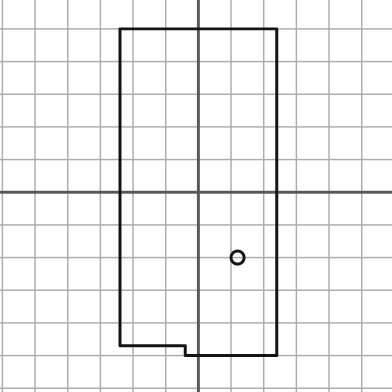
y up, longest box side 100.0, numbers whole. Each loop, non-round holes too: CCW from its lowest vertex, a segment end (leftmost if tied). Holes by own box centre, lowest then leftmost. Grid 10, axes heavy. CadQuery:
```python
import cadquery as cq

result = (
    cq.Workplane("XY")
    .moveTo(-4.0, -50.0)
    .lineTo(24.0, -50.0)
    .lineTo(24.0, 50.0)
    .lineTo(-24.0, 50.0)
    .lineTo(-24.0, -47.0)
    .lineTo(-4.0, -47.0)
    .close()
    .moveTo(12.0, -20.0)
    .circle(2.0)
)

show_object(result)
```